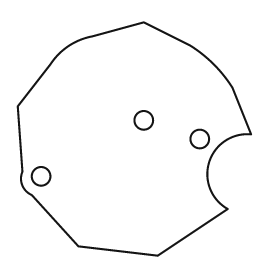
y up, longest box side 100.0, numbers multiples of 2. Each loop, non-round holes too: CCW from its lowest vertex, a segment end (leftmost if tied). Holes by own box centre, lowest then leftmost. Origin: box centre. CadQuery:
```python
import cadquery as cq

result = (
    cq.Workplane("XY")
    .moveTo(10.0, -50.0)
    .lineTo(40.0, -30.0)
    .threePointArc((32.0, -10.0), (50.0, 2.0))
    .lineTo(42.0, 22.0)
    .threePointArc((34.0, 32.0), (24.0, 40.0))
    .lineTo(4.0, 50.0)
    .lineTo(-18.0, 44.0)
    .threePointArc((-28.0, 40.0), (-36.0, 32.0))
    .lineTo(-50.0, 14.0)
    .lineTo(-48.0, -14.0)
    .threePointArc((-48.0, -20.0), (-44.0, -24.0))
    .lineTo(-24.0, -46.0)
    .close()
    .moveTo(-40.0, -16.0)
    .circle(4.0)
    .moveTo(28.0, 0.0)
    .circle(4.0)
    .moveTo(4.0, 8.0)
    .circle(4.0)
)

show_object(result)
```